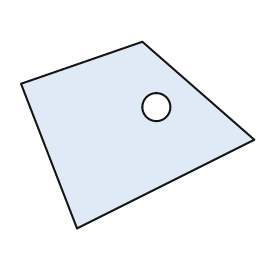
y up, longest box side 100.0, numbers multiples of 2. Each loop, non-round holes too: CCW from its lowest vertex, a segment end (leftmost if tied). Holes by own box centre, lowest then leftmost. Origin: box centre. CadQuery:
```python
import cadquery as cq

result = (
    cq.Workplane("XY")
    .moveTo(-26.0, -40.0)
    .lineTo(50.0, -2.0)
    .lineTo(2.0, 40.0)
    .lineTo(-50.0, 22.0)
    .close()
    .moveTo(8.0, 12.0)
    .circle(6.0)
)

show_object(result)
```